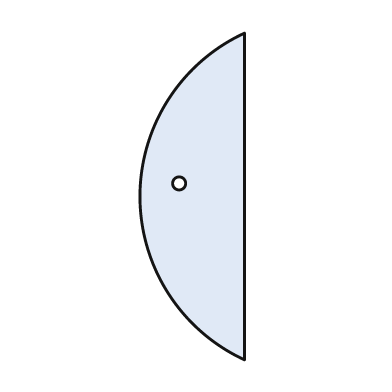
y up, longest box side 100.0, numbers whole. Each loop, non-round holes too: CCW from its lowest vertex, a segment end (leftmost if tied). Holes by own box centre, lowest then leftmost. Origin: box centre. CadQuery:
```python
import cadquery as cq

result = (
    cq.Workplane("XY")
    .moveTo(16.0, -50.0)
    .lineTo(16.0, 50.0)
    .threePointArc((-16.0, 0.0), (16.0, -50.0))
    .close()
    .moveTo(-4.0, 4.0)
    .circle(2.0)
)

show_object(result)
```